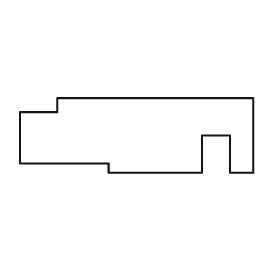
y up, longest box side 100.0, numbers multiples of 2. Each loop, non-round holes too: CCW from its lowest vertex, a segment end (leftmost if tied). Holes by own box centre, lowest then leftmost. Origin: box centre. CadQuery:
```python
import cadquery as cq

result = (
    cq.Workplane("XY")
    .moveTo(-12.0, -16.0)
    .lineTo(28.0, -16.0)
    .lineTo(28.0, 0.0)
    .lineTo(40.0, 0.0)
    .lineTo(40.0, -16.0)
    .lineTo(50.0, -16.0)
    .lineTo(50.0, 16.0)
    .lineTo(-34.0, 16.0)
    .lineTo(-34.0, 10.0)
    .lineTo(-50.0, 10.0)
    .lineTo(-50.0, -12.0)
    .lineTo(-12.0, -12.0)
    .close()
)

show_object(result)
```